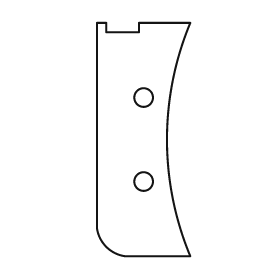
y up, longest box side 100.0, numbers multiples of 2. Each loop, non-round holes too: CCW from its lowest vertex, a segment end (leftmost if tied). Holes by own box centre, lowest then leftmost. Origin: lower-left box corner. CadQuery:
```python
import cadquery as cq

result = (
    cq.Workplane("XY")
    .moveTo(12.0, 0.0)
    .lineTo(40.0, 0.0)
    .threePointArc((30.0, 50.0), (40.0, 100.0))
    .lineTo(18.0, 100.0)
    .lineTo(18.0, 96.0)
    .lineTo(4.0, 96.0)
    .lineTo(4.0, 100.0)
    .lineTo(0.0, 100.0)
    .lineTo(0.0, 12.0)
    .threePointArc((4.0, 4.0), (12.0, 0.0))
    .close()
    .moveTo(20.0, 32.0)
    .circle(4.0)
    .moveTo(20.0, 68.0)
    .circle(4.0)
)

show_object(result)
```